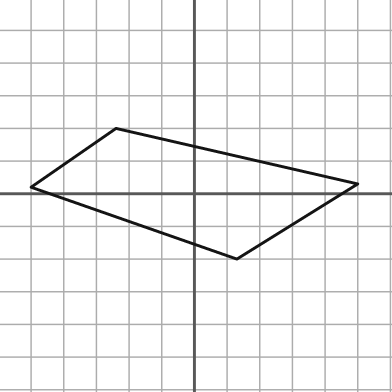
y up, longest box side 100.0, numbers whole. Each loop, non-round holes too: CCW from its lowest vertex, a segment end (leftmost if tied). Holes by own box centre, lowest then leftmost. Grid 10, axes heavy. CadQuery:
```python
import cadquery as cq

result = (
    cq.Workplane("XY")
    .moveTo(13.0, -20.0)
    .lineTo(50.0, 3.0)
    .lineTo(-24.0, 20.0)
    .lineTo(-50.0, 2.0)
    .close()
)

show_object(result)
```